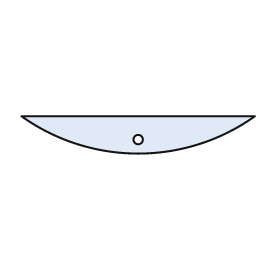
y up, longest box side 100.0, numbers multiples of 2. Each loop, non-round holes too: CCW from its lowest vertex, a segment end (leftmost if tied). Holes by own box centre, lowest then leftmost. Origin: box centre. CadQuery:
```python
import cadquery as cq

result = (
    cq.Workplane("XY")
    .moveTo(-50.0, 8.0)
    .threePointArc((0.0, -8.0), (50.0, 8.0))
    .close()
    .moveTo(0.0, -2.0)
    .circle(2.0)
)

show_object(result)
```